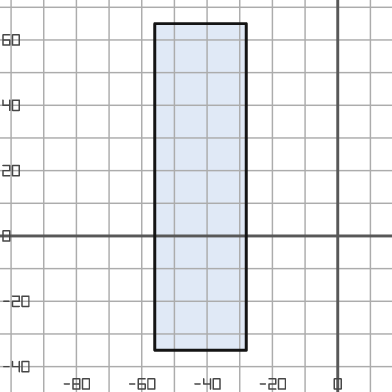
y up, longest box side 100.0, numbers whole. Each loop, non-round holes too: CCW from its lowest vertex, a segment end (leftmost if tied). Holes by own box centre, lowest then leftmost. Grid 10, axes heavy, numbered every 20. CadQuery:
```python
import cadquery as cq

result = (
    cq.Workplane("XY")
    .moveTo(-56.0, -35.0)
    .lineTo(-28.0, -35.0)
    .lineTo(-28.0, 65.0)
    .lineTo(-56.0, 65.0)
    .close()
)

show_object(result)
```